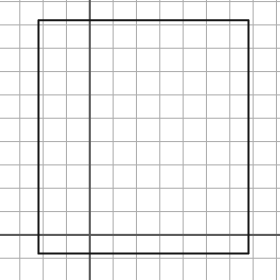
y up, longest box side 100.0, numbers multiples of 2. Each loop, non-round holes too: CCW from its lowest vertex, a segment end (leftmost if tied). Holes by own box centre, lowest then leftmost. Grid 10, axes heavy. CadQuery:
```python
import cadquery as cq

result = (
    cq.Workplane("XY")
    .moveTo(-22.0, -8.0)
    .lineTo(68.0, -8.0)
    .lineTo(68.0, 92.0)
    .lineTo(-22.0, 92.0)
    .close()
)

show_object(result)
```